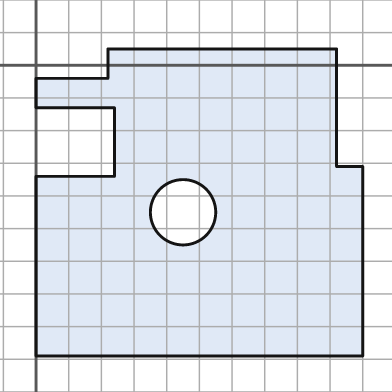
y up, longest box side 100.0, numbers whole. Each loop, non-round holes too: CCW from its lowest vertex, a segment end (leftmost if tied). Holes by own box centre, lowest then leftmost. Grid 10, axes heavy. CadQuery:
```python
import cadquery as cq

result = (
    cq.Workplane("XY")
    .moveTo(0.0, -89.0)
    .lineTo(100.0, -89.0)
    .lineTo(100.0, -31.0)
    .lineTo(92.0, -31.0)
    .lineTo(92.0, 5.0)
    .lineTo(22.0, 5.0)
    .lineTo(22.0, -4.0)
    .lineTo(0.0, -4.0)
    .lineTo(0.0, -13.0)
    .lineTo(24.0, -13.0)
    .lineTo(24.0, -34.0)
    .lineTo(0.0, -34.0)
    .close()
    .moveTo(45.0, -45.0)
    .circle(10.0)
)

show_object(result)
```